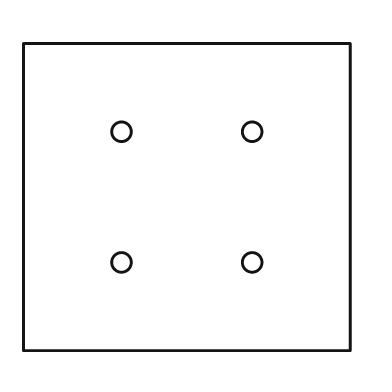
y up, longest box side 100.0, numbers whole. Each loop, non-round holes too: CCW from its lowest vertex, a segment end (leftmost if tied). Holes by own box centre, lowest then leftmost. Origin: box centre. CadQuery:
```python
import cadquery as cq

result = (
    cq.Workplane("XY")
    .moveTo(-50.0, -47.0)
    .lineTo(50.0, -47.0)
    .lineTo(50.0, 47.0)
    .lineTo(-50.0, 47.0)
    .close()
    .moveTo(-20.0, -20.0)
    .circle(3.0)
    .moveTo(20.0, -20.0)
    .circle(3.0)
    .moveTo(-20.0, 20.0)
    .circle(3.0)
    .moveTo(20.0, 20.0)
    .circle(3.0)
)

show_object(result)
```